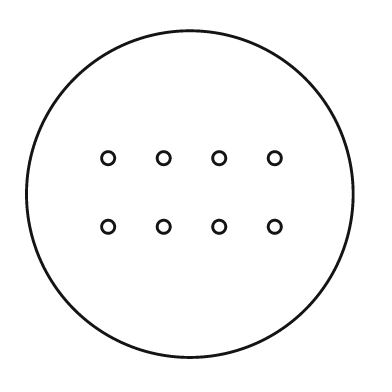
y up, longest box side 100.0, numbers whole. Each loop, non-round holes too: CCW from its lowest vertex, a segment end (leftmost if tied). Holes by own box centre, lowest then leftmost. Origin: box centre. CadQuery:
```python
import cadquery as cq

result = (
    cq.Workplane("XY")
    .moveTo(0.0, 0.0)
    .circle(50.0)
    .moveTo(-25.0, -10.0)
    .circle(2.0)
    .moveTo(-8.0, -10.0)
    .circle(2.0)
    .moveTo(9.0, -10.0)
    .circle(2.0)
    .moveTo(26.0, -10.0)
    .circle(2.0)
    .moveTo(-25.0, 11.0)
    .circle(2.0)
    .moveTo(-8.0, 11.0)
    .circle(2.0)
    .moveTo(9.0, 11.0)
    .circle(2.0)
    .moveTo(26.0, 11.0)
    .circle(2.0)
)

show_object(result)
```